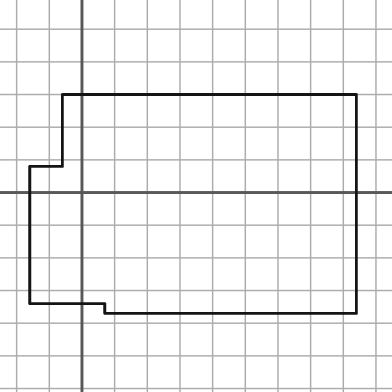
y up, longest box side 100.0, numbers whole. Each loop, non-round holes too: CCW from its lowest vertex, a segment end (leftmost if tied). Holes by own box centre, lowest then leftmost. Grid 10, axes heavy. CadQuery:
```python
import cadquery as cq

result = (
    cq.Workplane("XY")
    .moveTo(7.0, -37.0)
    .lineTo(84.0, -37.0)
    .lineTo(84.0, 30.0)
    .lineTo(-6.0, 30.0)
    .lineTo(-6.0, 8.0)
    .lineTo(-16.0, 8.0)
    .lineTo(-16.0, -34.0)
    .lineTo(7.0, -34.0)
    .close()
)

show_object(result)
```